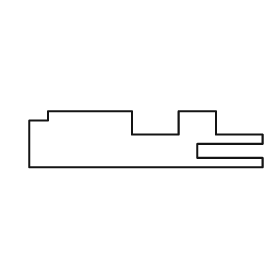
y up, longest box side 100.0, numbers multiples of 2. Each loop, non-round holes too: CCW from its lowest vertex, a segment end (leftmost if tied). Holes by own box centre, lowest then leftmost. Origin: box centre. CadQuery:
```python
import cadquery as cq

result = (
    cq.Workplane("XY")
    .moveTo(-50.0, -12.0)
    .lineTo(50.0, -12.0)
    .lineTo(50.0, -8.0)
    .lineTo(22.0, -8.0)
    .lineTo(22.0, -2.0)
    .lineTo(50.0, -2.0)
    .lineTo(50.0, 2.0)
    .lineTo(30.0, 2.0)
    .lineTo(30.0, 12.0)
    .lineTo(14.0, 12.0)
    .lineTo(14.0, 2.0)
    .lineTo(-6.0, 2.0)
    .lineTo(-6.0, 12.0)
    .lineTo(-42.0, 12.0)
    .lineTo(-42.0, 8.0)
    .lineTo(-50.0, 8.0)
    .close()
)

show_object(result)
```